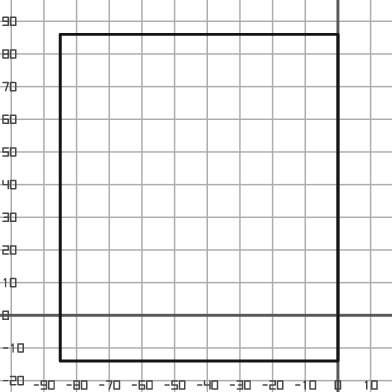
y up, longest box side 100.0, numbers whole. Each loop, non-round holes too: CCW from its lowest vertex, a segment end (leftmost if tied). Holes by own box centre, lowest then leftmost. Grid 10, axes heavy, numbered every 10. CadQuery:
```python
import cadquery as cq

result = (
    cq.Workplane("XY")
    .moveTo(-85.0, -14.0)
    .lineTo(0.0, -14.0)
    .lineTo(0.0, 86.0)
    .lineTo(-85.0, 86.0)
    .close()
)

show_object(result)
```